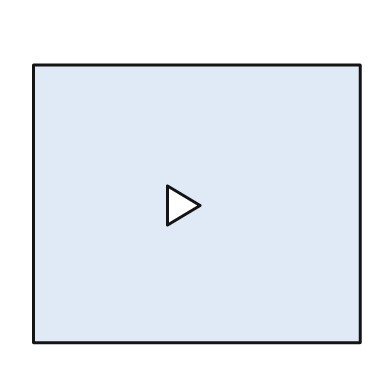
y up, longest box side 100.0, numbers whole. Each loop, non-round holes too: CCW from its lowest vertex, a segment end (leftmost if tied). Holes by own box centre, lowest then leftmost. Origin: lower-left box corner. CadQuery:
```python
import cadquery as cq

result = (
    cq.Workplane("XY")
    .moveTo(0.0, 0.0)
    .lineTo(100.0, 0.0)
    .lineTo(100.0, 85.0)
    .lineTo(0.0, 85.0)
    .close()
    .moveTo(41.0, 36.0)
    .lineTo(51.0, 42.0)
    .lineTo(41.0, 48.0)
    .close()
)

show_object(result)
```